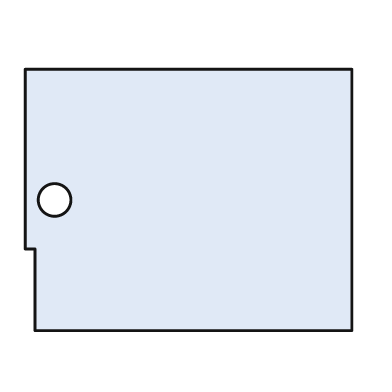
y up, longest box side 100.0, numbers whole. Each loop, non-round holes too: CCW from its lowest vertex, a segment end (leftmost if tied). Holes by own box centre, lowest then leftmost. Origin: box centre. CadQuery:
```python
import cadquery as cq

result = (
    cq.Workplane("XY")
    .moveTo(-47.0, -40.0)
    .lineTo(50.0, -40.0)
    .lineTo(50.0, 40.0)
    .lineTo(-50.0, 40.0)
    .lineTo(-50.0, -15.0)
    .lineTo(-47.0, -15.0)
    .close()
    .moveTo(-41.0, 0.0)
    .circle(5.0)
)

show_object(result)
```